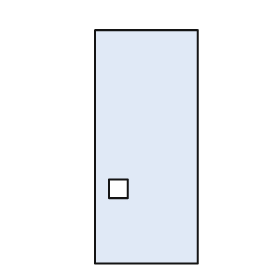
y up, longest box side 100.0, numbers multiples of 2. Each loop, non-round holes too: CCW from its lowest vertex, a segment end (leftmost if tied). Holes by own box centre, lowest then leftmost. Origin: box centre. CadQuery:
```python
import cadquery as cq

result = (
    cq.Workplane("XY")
    .moveTo(-22.0, -50.0)
    .lineTo(22.0, -50.0)
    .lineTo(22.0, 50.0)
    .lineTo(-22.0, 50.0)
    .close()
    .moveTo(-16.0, -22.0)
    .lineTo(-8.0, -22.0)
    .lineTo(-8.0, -14.0)
    .lineTo(-16.0, -14.0)
    .close()
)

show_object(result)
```